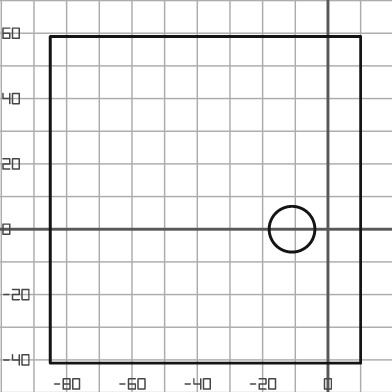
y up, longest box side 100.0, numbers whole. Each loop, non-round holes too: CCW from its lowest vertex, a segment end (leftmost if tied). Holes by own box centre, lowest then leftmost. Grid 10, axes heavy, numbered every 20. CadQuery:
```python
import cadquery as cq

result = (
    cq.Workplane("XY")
    .moveTo(-85.0, -41.0)
    .lineTo(10.0, -41.0)
    .lineTo(10.0, 59.0)
    .lineTo(-85.0, 59.0)
    .close()
    .moveTo(-11.0, 0.0)
    .circle(7.0)
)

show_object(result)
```